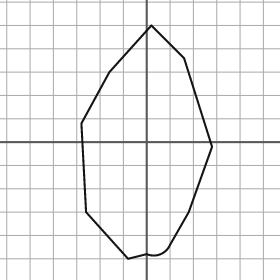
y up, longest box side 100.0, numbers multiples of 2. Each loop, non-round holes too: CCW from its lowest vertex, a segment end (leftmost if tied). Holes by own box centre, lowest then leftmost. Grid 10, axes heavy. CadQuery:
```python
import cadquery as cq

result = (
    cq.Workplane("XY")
    .moveTo(-8.0, -50.0)
    .lineTo(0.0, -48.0)
    .threePointArc((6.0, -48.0), (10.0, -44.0))
    .lineTo(18.0, -30.0)
    .lineTo(28.0, -2.0)
    .lineTo(16.0, 36.0)
    .lineTo(2.0, 50.0)
    .lineTo(-16.0, 30.0)
    .lineTo(-28.0, 8.0)
    .lineTo(-26.0, -30.0)
    .close()
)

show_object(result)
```